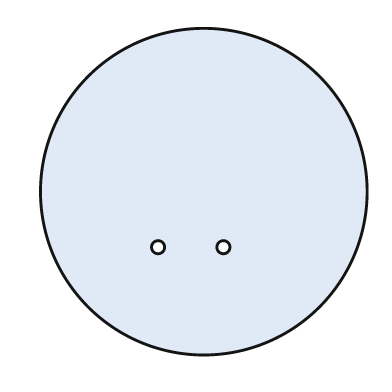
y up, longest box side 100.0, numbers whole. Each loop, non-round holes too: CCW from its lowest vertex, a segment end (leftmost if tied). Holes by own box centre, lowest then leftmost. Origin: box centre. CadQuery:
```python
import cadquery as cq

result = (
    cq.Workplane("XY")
    .moveTo(0.0, 0.0)
    .circle(50.0)
    .moveTo(-14.0, -17.0)
    .circle(2.0)
    .moveTo(6.0, -17.0)
    .circle(2.0)
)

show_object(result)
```